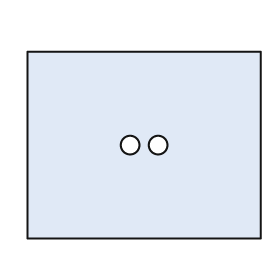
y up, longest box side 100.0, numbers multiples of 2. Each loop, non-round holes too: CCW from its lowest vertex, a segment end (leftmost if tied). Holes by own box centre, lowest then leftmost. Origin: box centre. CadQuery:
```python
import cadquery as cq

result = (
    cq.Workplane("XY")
    .moveTo(-50.0, -40.0)
    .lineTo(50.0, -40.0)
    .lineTo(50.0, 40.0)
    .lineTo(-50.0, 40.0)
    .close()
    .moveTo(-6.0, 0.0)
    .circle(4.0)
    .moveTo(6.0, 0.0)
    .circle(4.0)
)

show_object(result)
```